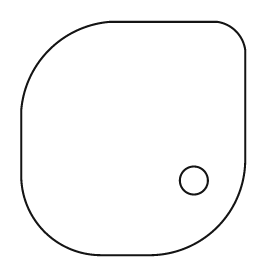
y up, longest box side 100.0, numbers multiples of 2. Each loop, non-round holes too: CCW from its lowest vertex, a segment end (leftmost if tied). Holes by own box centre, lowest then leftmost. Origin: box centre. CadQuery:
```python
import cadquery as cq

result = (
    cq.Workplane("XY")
    .moveTo(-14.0, -50.0)
    .lineTo(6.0, -50.0)
    .threePointArc((36.0, -38.0), (48.0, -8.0))
    .lineTo(48.0, 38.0)
    .threePointArc((44.0, 46.0), (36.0, 50.0))
    .lineTo(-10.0, 50.0)
    .threePointArc((-36.0, 38.0), (-48.0, 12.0))
    .lineTo(-48.0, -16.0)
    .threePointArc((-38.0, -40.0), (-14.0, -50.0))
    .close()
    .moveTo(26.0, -18.0)
    .circle(6.0)
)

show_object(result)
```